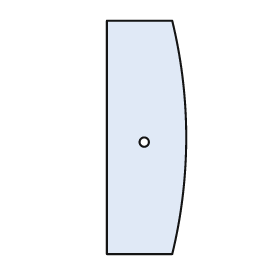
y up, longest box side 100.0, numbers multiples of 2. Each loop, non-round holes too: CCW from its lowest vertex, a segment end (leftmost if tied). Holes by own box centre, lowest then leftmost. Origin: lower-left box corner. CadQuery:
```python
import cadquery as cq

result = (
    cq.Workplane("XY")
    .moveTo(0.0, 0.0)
    .lineTo(28.0, 0.0)
    .threePointArc((34.0, 50.0), (28.0, 100.0))
    .lineTo(0.0, 100.0)
    .close()
    .moveTo(16.0, 48.0)
    .circle(2.0)
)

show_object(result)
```